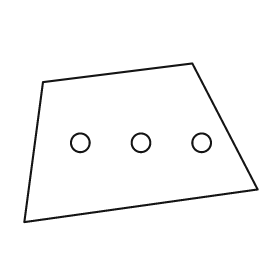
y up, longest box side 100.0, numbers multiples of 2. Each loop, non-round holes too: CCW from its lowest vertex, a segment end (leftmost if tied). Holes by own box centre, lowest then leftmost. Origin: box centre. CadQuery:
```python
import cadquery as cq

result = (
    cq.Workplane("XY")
    .moveTo(-50.0, -34.0)
    .lineTo(50.0, -20.0)
    .lineTo(22.0, 34.0)
    .lineTo(-42.0, 26.0)
    .close()
    .moveTo(-26.0, 0.0)
    .circle(4.0)
    .moveTo(0.0, 0.0)
    .circle(4.0)
    .moveTo(26.0, 0.0)
    .circle(4.0)
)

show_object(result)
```